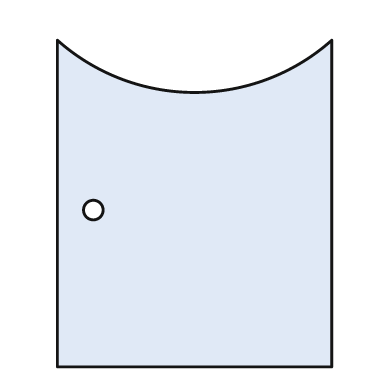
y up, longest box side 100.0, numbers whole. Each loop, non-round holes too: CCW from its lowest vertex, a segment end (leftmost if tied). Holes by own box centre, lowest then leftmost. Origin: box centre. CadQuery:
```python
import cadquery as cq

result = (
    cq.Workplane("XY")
    .moveTo(-42.0, -50.0)
    .lineTo(42.0, -50.0)
    .lineTo(42.0, 50.0)
    .threePointArc((0.0, 34.0), (-42.0, 50.0))
    .close()
    .moveTo(-31.0, -2.0)
    .circle(3.0)
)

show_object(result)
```